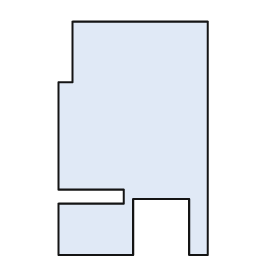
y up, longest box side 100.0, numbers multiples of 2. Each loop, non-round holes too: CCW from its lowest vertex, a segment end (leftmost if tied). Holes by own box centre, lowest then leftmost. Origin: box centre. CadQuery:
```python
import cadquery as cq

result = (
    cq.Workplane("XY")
    .moveTo(-32.0, -50.0)
    .lineTo(0.0, -50.0)
    .lineTo(0.0, -26.0)
    .lineTo(24.0, -26.0)
    .lineTo(24.0, -50.0)
    .lineTo(32.0, -50.0)
    .lineTo(32.0, 50.0)
    .lineTo(-26.0, 50.0)
    .lineTo(-26.0, 24.0)
    .lineTo(-32.0, 24.0)
    .lineTo(-32.0, -22.0)
    .lineTo(-4.0, -22.0)
    .lineTo(-4.0, -28.0)
    .lineTo(-32.0, -28.0)
    .close()
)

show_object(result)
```